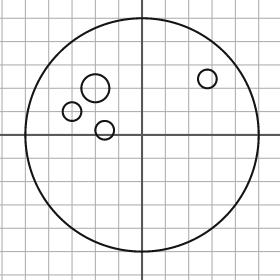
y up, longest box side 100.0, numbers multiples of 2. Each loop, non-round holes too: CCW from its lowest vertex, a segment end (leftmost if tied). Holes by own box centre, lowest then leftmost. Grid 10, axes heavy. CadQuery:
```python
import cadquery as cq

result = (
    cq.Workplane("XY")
    .moveTo(0.0, 0.0)
    .circle(50.0)
    .moveTo(-16.0, 2.0)
    .circle(4.0)
    .moveTo(-30.0, 10.0)
    .circle(4.0)
    .moveTo(-20.0, 20.0)
    .circle(6.0)
    .moveTo(28.0, 24.0)
    .circle(4.0)
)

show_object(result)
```